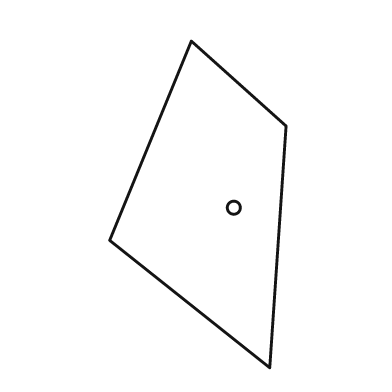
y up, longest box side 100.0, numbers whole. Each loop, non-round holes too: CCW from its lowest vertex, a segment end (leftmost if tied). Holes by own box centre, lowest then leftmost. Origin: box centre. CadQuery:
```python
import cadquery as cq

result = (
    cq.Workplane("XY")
    .moveTo(22.0, -50.0)
    .lineTo(27.0, 24.0)
    .lineTo(-2.0, 50.0)
    .lineTo(-27.0, -11.0)
    .close()
    .moveTo(11.0, -1.0)
    .circle(2.0)
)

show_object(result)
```